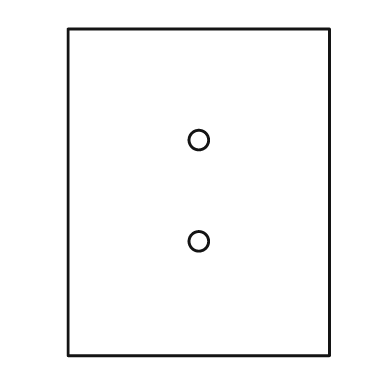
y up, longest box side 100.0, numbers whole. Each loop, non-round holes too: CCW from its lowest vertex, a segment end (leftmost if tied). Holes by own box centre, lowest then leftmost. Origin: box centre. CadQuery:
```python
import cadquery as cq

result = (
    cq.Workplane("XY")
    .moveTo(-40.0, -50.0)
    .lineTo(40.0, -50.0)
    .lineTo(40.0, 50.0)
    .lineTo(-40.0, 50.0)
    .close()
    .moveTo(0.0, -15.0)
    .circle(3.0)
    .moveTo(0.0, 16.0)
    .circle(3.0)
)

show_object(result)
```